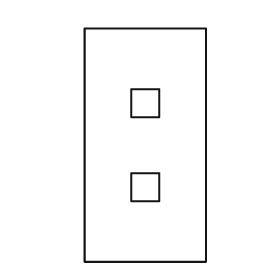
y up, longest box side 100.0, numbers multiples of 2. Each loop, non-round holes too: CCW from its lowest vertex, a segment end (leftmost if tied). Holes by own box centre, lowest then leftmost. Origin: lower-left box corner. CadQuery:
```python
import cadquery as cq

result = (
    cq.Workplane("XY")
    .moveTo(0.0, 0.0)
    .lineTo(52.0, 0.0)
    .lineTo(52.0, 100.0)
    .lineTo(0.0, 100.0)
    .close()
    .moveTo(20.0, 26.0)
    .lineTo(32.0, 26.0)
    .lineTo(32.0, 38.0)
    .lineTo(20.0, 38.0)
    .close()
    .moveTo(20.0, 62.0)
    .lineTo(32.0, 62.0)
    .lineTo(32.0, 74.0)
    .lineTo(20.0, 74.0)
    .close()
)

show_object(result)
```